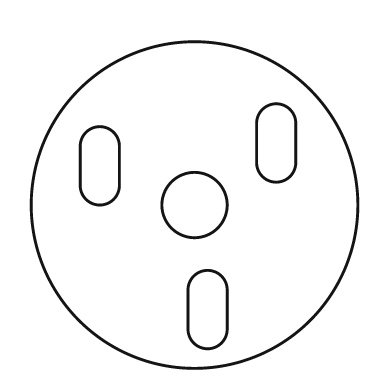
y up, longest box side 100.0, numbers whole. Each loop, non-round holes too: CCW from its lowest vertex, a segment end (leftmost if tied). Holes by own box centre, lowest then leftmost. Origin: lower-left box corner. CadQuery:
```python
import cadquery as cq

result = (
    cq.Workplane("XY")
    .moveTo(50.0, 50.0)
    .circle(50.0)
    .moveTo(48.0, 12.0)
    .threePointArc((54.0, 6.0), (60.0, 12.0))
    .lineTo(60.0, 24.0)
    .threePointArc((54.0, 30.0), (48.0, 24.0))
    .close()
    .moveTo(50.0, 50.0)
    .circle(10.0)
    .moveTo(15.0, 56.0)
    .threePointArc((21.0, 50.0), (27.0, 56.0))
    .lineTo(27.0, 68.0)
    .threePointArc((21.0, 74.0), (15.0, 68.0))
    .close()
    .moveTo(69.0, 63.0)
    .threePointArc((75.0, 57.0), (81.0, 63.0))
    .lineTo(81.0, 75.0)
    .threePointArc((75.0, 81.0), (69.0, 75.0))
    .close()
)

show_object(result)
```